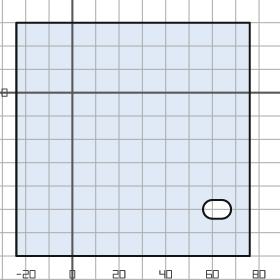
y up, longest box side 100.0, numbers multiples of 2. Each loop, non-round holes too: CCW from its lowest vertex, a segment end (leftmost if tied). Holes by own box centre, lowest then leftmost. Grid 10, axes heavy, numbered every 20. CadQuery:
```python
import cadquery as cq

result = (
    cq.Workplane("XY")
    .moveTo(-24.0, -70.0)
    .lineTo(76.0, -70.0)
    .lineTo(76.0, 30.0)
    .lineTo(-24.0, 30.0)
    .close()
    .moveTo(60.0, -54.0)
    .lineTo(64.0, -54.0)
    .threePointArc((68.0, -50.0), (64.0, -46.0))
    .lineTo(60.0, -46.0)
    .threePointArc((56.0, -50.0), (60.0, -54.0))
    .close()
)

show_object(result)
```